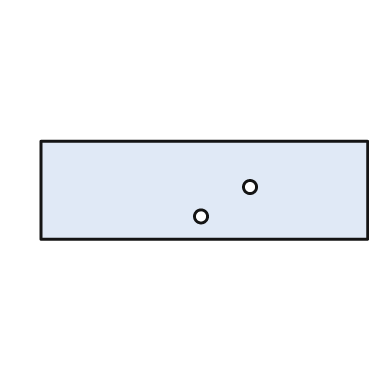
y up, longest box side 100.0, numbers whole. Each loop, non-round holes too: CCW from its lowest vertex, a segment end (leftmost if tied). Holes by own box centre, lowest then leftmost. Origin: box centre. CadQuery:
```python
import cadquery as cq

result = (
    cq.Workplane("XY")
    .moveTo(-50.0, -15.0)
    .lineTo(50.0, -15.0)
    .lineTo(50.0, 15.0)
    .lineTo(-50.0, 15.0)
    .close()
    .moveTo(-1.0, -8.0)
    .circle(2.0)
    .moveTo(14.0, 1.0)
    .circle(2.0)
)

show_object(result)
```